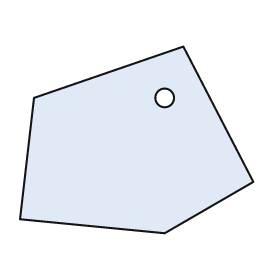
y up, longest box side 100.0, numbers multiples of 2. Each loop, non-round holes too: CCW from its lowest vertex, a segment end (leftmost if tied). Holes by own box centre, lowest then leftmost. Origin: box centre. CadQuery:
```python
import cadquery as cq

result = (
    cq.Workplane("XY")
    .moveTo(12.0, -40.0)
    .lineTo(50.0, -18.0)
    .lineTo(20.0, 40.0)
    .lineTo(-44.0, 18.0)
    .lineTo(-50.0, -34.0)
    .close()
    .moveTo(12.0, 18.0)
    .circle(4.0)
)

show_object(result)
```